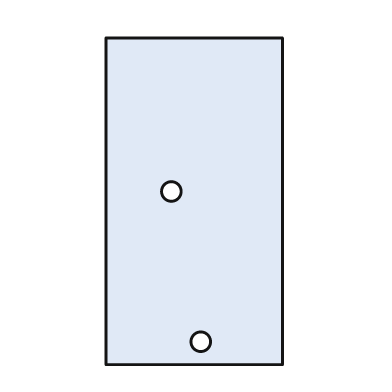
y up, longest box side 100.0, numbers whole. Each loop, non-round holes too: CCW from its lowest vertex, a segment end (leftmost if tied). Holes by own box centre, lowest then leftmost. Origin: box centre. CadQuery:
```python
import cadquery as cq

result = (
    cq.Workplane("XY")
    .moveTo(-27.0, -50.0)
    .lineTo(27.0, -50.0)
    .lineTo(27.0, 50.0)
    .lineTo(-27.0, 50.0)
    .close()
    .moveTo(2.0, -43.0)
    .circle(3.0)
    .moveTo(-7.0, 3.0)
    .circle(3.0)
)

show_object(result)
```